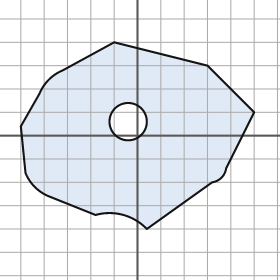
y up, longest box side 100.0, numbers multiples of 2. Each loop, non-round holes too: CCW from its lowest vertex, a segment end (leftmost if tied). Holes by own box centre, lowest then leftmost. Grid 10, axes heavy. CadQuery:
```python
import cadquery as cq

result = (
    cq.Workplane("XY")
    .moveTo(4.0, -40.0)
    .lineTo(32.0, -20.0)
    .threePointArc((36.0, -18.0), (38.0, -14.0))
    .lineTo(50.0, 10.0)
    .lineTo(30.0, 30.0)
    .lineTo(-10.0, 40.0)
    .lineTo(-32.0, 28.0)
    .threePointArc((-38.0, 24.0), (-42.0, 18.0))
    .lineTo(-50.0, 4.0)
    .lineTo(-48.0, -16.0)
    .threePointArc((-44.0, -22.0), (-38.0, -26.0))
    .lineTo(-18.0, -34.0)
    .threePointArc((-6.0, -34.0), (4.0, -40.0))
    .close()
    .moveTo(-4.0, 6.0)
    .circle(8.0)
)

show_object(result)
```